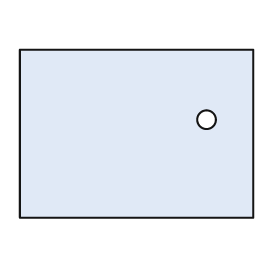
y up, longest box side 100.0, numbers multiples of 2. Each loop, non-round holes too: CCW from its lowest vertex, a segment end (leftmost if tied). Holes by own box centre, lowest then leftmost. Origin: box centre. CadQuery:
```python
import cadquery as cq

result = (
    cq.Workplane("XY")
    .moveTo(-50.0, -36.0)
    .lineTo(50.0, -36.0)
    .lineTo(50.0, 36.0)
    .lineTo(-50.0, 36.0)
    .close()
    .moveTo(30.0, 6.0)
    .circle(4.0)
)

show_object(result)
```